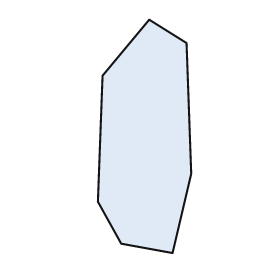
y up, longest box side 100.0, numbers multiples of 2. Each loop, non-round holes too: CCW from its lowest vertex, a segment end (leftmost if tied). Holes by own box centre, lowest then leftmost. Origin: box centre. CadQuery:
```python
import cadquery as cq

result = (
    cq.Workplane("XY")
    .moveTo(12.0, -50.0)
    .lineTo(20.0, -16.0)
    .lineTo(18.0, 40.0)
    .lineTo(2.0, 50.0)
    .lineTo(-18.0, 26.0)
    .lineTo(-20.0, -28.0)
    .lineTo(-10.0, -46.0)
    .close()
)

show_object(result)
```